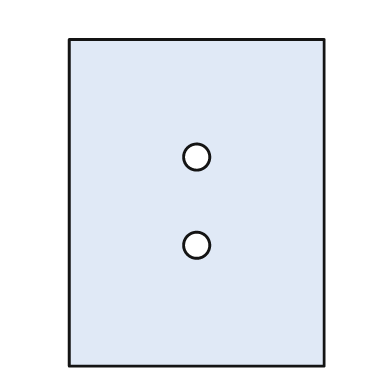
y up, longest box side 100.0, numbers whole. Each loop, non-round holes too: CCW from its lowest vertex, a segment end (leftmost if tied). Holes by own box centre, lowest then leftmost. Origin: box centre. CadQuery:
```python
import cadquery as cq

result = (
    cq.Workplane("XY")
    .moveTo(-39.0, -50.0)
    .lineTo(39.0, -50.0)
    .lineTo(39.0, 50.0)
    .lineTo(-39.0, 50.0)
    .close()
    .moveTo(0.0, -13.0)
    .circle(4.0)
    .moveTo(0.0, 14.0)
    .circle(4.0)
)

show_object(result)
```